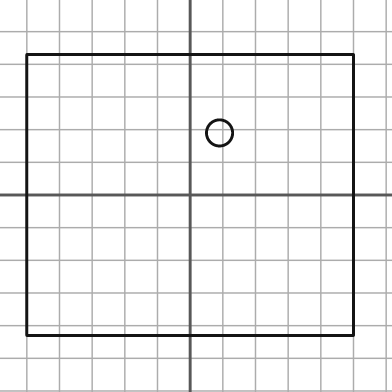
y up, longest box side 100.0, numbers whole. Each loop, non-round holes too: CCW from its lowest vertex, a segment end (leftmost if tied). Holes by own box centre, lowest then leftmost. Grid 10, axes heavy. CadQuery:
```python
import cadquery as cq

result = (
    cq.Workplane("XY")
    .moveTo(-50.0, -43.0)
    .lineTo(50.0, -43.0)
    .lineTo(50.0, 43.0)
    .lineTo(-50.0, 43.0)
    .close()
    .moveTo(9.0, 19.0)
    .circle(4.0)
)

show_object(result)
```